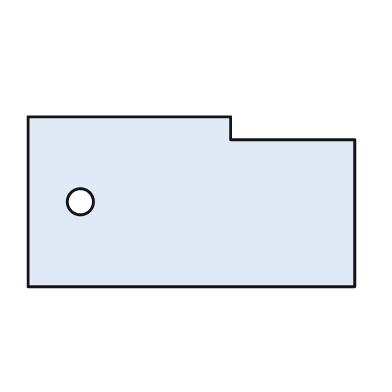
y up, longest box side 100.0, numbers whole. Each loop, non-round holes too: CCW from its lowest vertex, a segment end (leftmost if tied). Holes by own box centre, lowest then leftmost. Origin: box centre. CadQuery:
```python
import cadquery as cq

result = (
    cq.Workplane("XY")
    .moveTo(-50.0, -26.0)
    .lineTo(50.0, -26.0)
    .lineTo(50.0, 19.0)
    .lineTo(12.0, 19.0)
    .lineTo(12.0, 26.0)
    .lineTo(-50.0, 26.0)
    .close()
    .moveTo(-34.0, 0.0)
    .circle(4.0)
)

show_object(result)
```